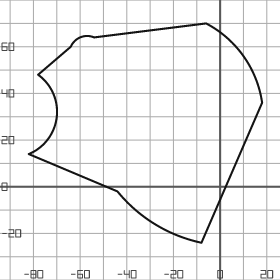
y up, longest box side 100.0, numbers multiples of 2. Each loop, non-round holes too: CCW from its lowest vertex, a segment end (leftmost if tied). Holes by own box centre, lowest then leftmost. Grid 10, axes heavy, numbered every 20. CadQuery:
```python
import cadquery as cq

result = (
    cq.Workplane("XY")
    .moveTo(-8.0, -24.0)
    .lineTo(18.0, 36.0)
    .threePointArc((10.0, 56.0), (-6.0, 70.0))
    .lineTo(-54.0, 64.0)
    .threePointArc((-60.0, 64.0), (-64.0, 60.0))
    .lineTo(-78.0, 48.0)
    .threePointArc((-70.0, 30.0), (-82.0, 14.0))
    .lineTo(-44.0, -2.0)
    .threePointArc((-28.0, -16.0), (-8.0, -24.0))
    .close()
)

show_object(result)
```